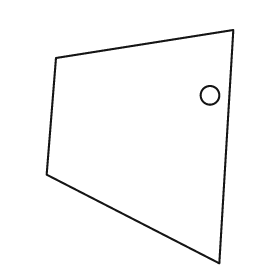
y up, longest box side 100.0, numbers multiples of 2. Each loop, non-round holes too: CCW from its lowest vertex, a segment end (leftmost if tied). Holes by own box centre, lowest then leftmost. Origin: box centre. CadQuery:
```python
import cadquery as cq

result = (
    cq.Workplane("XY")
    .moveTo(34.0, -50.0)
    .lineTo(40.0, 50.0)
    .lineTo(-36.0, 38.0)
    .lineTo(-40.0, -12.0)
    .close()
    .moveTo(30.0, 22.0)
    .circle(4.0)
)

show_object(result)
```